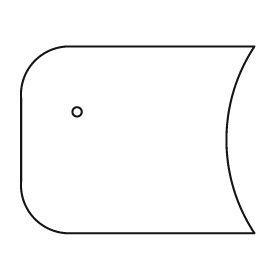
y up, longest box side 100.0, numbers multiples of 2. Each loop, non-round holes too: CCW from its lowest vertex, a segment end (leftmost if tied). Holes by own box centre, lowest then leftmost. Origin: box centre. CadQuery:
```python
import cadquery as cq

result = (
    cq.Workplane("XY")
    .moveTo(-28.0, -40.0)
    .lineTo(50.0, -40.0)
    .threePointArc((38.0, 0.0), (50.0, 40.0))
    .lineTo(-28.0, 40.0)
    .threePointArc((-44.0, 34.0), (-50.0, 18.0))
    .lineTo(-50.0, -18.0)
    .threePointArc((-44.0, -34.0), (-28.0, -40.0))
    .close()
    .moveTo(-26.0, 12.0)
    .circle(2.0)
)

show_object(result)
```